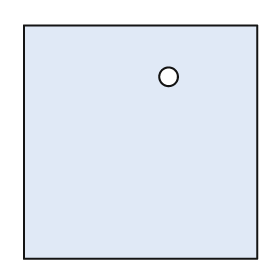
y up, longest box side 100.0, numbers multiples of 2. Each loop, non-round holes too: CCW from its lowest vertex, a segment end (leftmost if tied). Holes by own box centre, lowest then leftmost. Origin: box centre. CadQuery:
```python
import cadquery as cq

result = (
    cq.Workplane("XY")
    .moveTo(-50.0, -50.0)
    .lineTo(50.0, -50.0)
    .lineTo(50.0, 50.0)
    .lineTo(-50.0, 50.0)
    .close()
    .moveTo(12.0, 28.0)
    .circle(4.0)
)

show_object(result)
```